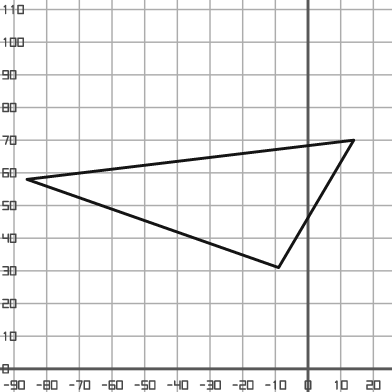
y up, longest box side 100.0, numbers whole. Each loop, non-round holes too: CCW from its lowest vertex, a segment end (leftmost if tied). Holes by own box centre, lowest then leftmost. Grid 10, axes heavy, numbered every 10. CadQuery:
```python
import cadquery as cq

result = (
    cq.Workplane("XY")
    .moveTo(-9.0, 31.0)
    .lineTo(14.0, 70.0)
    .lineTo(-86.0, 58.0)
    .close()
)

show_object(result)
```